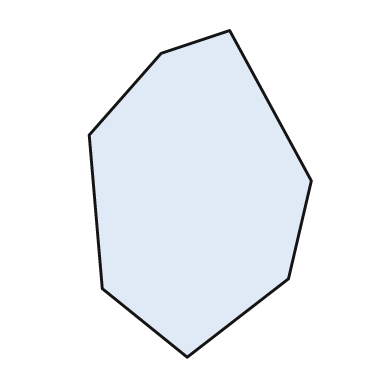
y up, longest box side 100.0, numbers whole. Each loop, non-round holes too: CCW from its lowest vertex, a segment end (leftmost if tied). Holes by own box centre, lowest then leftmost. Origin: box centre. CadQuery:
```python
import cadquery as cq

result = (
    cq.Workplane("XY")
    .moveTo(-4.0, -50.0)
    .lineTo(27.0, -26.0)
    .lineTo(34.0, 4.0)
    .lineTo(9.0, 50.0)
    .lineTo(-12.0, 43.0)
    .lineTo(-34.0, 18.0)
    .lineTo(-30.0, -29.0)
    .close()
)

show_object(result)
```